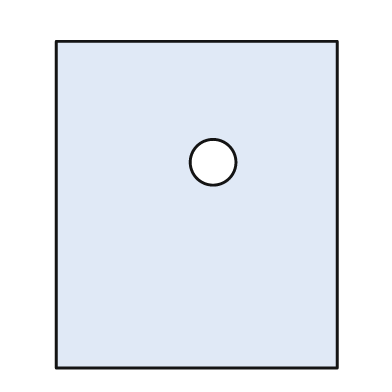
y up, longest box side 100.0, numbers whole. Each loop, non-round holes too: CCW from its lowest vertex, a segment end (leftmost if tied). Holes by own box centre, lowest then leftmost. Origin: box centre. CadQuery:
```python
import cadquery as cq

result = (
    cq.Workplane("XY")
    .moveTo(-43.0, -50.0)
    .lineTo(43.0, -50.0)
    .lineTo(43.0, 50.0)
    .lineTo(-43.0, 50.0)
    .close()
    .moveTo(5.0, 13.0)
    .circle(7.0)
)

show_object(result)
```